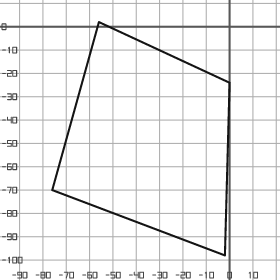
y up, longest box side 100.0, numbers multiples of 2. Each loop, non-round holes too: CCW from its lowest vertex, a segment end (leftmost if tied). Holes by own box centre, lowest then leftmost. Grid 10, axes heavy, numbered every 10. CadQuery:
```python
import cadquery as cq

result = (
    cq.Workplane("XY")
    .moveTo(-2.0, -98.0)
    .lineTo(0.0, -24.0)
    .lineTo(-56.0, 2.0)
    .lineTo(-76.0, -70.0)
    .close()
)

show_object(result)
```